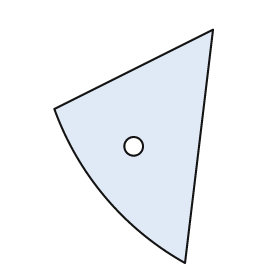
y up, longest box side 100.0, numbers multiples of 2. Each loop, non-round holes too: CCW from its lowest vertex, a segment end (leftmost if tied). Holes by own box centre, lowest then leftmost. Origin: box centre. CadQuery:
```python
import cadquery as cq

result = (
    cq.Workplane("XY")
    .moveTo(22.0, -50.0)
    .lineTo(34.0, 50.0)
    .lineTo(-34.0, 16.0)
    .threePointArc((-12.0, -22.0), (22.0, -50.0))
    .close()
    .moveTo(0.0, 0.0)
    .circle(4.0)
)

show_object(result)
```